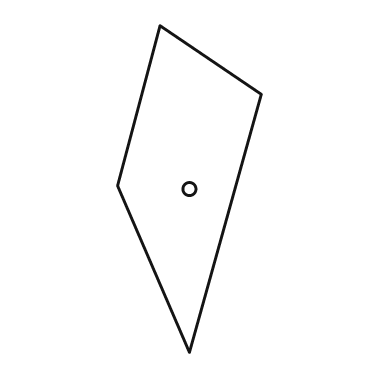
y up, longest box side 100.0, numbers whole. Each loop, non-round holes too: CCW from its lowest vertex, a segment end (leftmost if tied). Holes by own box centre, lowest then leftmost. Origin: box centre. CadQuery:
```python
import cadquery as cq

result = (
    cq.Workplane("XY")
    .moveTo(0.0, -50.0)
    .lineTo(22.0, 29.0)
    .lineTo(-9.0, 50.0)
    .lineTo(-22.0, 1.0)
    .close()
    .moveTo(0.0, 0.0)
    .circle(2.0)
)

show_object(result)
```